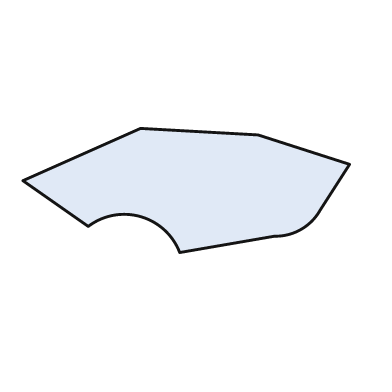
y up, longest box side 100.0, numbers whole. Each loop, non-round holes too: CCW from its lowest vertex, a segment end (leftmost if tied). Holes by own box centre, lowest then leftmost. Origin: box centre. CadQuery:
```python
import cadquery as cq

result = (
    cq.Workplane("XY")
    .moveTo(-2.0, -19.0)
    .lineTo(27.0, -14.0)
    .threePointArc((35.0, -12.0), (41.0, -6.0))
    .lineTo(50.0, 8.0)
    .lineTo(22.0, 17.0)
    .lineTo(-14.0, 19.0)
    .lineTo(-50.0, 3.0)
    .lineTo(-30.0, -11.0)
    .threePointArc((-14.0, -8.0), (-2.0, -19.0))
    .close()
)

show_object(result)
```